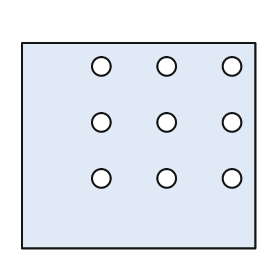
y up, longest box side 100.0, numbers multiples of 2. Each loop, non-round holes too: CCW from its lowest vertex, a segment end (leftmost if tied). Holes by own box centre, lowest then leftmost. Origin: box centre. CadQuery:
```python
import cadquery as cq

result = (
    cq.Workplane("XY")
    .moveTo(-50.0, -44.0)
    .lineTo(50.0, -44.0)
    .lineTo(50.0, 44.0)
    .lineTo(-50.0, 44.0)
    .close()
    .moveTo(-16.0, -14.0)
    .circle(4.0)
    .moveTo(12.0, -14.0)
    .circle(4.0)
    .moveTo(40.0, -14.0)
    .circle(4.0)
    .moveTo(-16.0, 10.0)
    .circle(4.0)
    .moveTo(12.0, 10.0)
    .circle(4.0)
    .moveTo(40.0, 10.0)
    .circle(4.0)
    .moveTo(-16.0, 34.0)
    .circle(4.0)
    .moveTo(12.0, 34.0)
    .circle(4.0)
    .moveTo(40.0, 34.0)
    .circle(4.0)
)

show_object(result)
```